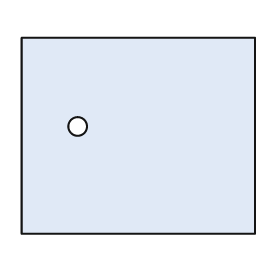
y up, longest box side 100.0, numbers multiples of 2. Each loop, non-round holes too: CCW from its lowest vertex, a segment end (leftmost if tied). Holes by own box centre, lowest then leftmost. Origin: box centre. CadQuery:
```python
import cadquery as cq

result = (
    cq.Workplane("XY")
    .moveTo(-50.0, -42.0)
    .lineTo(50.0, -42.0)
    .lineTo(50.0, 42.0)
    .lineTo(-50.0, 42.0)
    .close()
    .moveTo(-26.0, 4.0)
    .circle(4.0)
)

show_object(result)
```